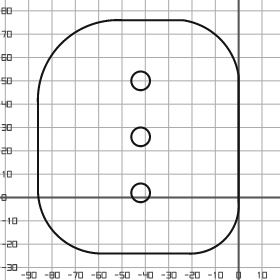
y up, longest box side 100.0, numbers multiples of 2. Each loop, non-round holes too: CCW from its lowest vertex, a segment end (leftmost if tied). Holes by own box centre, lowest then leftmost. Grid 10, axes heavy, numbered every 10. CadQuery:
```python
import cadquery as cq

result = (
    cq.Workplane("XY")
    .moveTo(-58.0, -24.0)
    .lineTo(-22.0, -24.0)
    .threePointArc((-6.0, -18.0), (0.0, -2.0))
    .lineTo(0.0, 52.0)
    .threePointArc((-8.0, 68.0), (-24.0, 76.0))
    .lineTo(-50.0, 76.0)
    .threePointArc((-76.0, 66.0), (-86.0, 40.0))
    .lineTo(-86.0, 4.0)
    .threePointArc((-78.0, -16.0), (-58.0, -24.0))
    .close()
    .moveTo(-42.0, 2.0)
    .circle(4.0)
    .moveTo(-42.0, 26.0)
    .circle(4.0)
    .moveTo(-42.0, 50.0)
    .circle(4.0)
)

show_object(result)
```